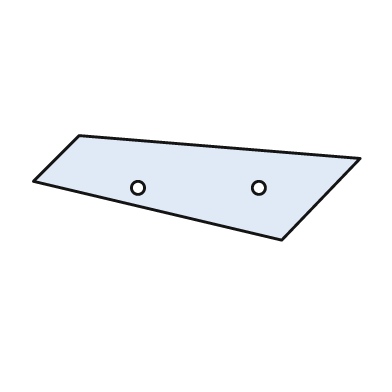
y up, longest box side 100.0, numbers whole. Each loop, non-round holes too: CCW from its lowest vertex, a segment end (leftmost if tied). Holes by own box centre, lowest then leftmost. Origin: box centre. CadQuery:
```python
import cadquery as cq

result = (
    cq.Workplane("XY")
    .moveTo(26.0, -16.0)
    .lineTo(50.0, 9.0)
    .lineTo(-36.0, 16.0)
    .lineTo(-50.0, 2.0)
    .close()
    .moveTo(-18.0, 0.0)
    .circle(2.0)
    .moveTo(19.0, 0.0)
    .circle(2.0)
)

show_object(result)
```